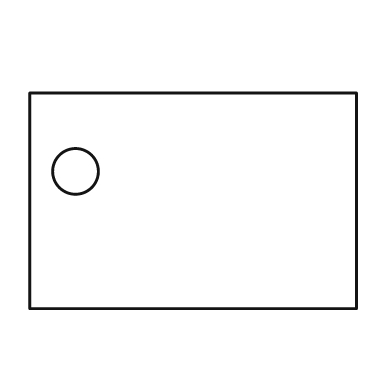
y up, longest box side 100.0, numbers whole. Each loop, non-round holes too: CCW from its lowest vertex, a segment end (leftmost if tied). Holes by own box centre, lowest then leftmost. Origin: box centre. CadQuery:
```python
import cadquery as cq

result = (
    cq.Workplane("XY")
    .moveTo(-50.0, -33.0)
    .lineTo(50.0, -33.0)
    .lineTo(50.0, 33.0)
    .lineTo(-50.0, 33.0)
    .close()
    .moveTo(-36.0, 9.0)
    .circle(7.0)
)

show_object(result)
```